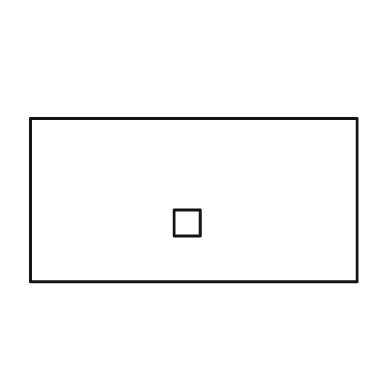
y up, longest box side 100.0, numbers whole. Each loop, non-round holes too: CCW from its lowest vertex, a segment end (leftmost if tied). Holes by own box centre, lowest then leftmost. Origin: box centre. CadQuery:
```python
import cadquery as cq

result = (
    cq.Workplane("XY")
    .moveTo(-50.0, -25.0)
    .lineTo(50.0, -25.0)
    .lineTo(50.0, 25.0)
    .lineTo(-50.0, 25.0)
    .close()
    .moveTo(-6.0, -11.0)
    .lineTo(2.0, -11.0)
    .lineTo(2.0, -3.0)
    .lineTo(-6.0, -3.0)
    .close()
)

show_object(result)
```